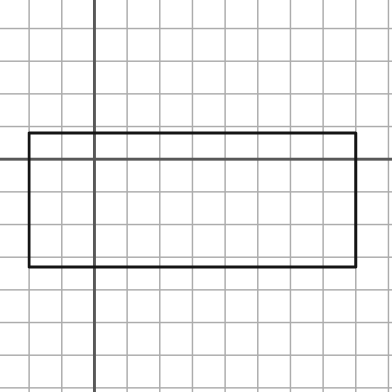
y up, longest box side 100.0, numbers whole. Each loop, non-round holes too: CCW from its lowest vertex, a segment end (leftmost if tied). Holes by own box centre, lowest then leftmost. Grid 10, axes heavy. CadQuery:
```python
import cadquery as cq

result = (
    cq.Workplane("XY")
    .moveTo(-20.0, -33.0)
    .lineTo(80.0, -33.0)
    .lineTo(80.0, 8.0)
    .lineTo(-20.0, 8.0)
    .close()
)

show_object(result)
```